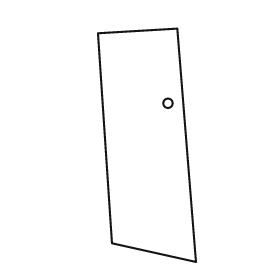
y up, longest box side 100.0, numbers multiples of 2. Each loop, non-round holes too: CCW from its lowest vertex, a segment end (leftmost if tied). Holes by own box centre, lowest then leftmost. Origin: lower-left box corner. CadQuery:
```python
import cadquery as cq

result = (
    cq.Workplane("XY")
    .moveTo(42.0, 0.0)
    .lineTo(34.0, 100.0)
    .lineTo(0.0, 98.0)
    .lineTo(6.0, 8.0)
    .close()
    .moveTo(30.0, 68.0)
    .circle(2.0)
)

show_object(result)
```